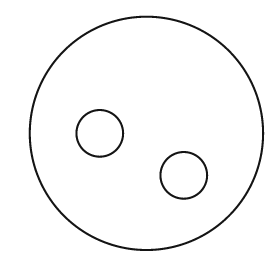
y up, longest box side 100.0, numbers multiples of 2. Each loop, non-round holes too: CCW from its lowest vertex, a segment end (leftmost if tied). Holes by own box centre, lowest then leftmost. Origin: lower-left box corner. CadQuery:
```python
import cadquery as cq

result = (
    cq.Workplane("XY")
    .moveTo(50.0, 50.0)
    .circle(50.0)
    .moveTo(66.0, 32.0)
    .circle(10.0)
    .moveTo(30.0, 50.0)
    .circle(10.0)
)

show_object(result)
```